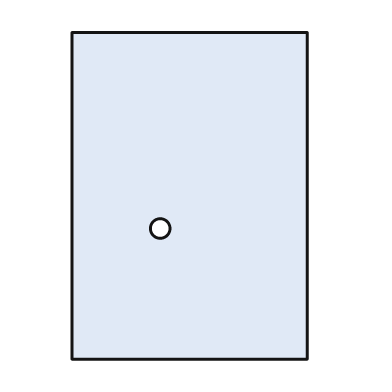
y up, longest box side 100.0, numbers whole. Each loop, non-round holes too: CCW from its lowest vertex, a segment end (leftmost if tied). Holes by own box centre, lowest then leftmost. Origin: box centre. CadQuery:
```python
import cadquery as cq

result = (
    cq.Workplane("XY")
    .moveTo(-36.0, -50.0)
    .lineTo(36.0, -50.0)
    .lineTo(36.0, 50.0)
    .lineTo(-36.0, 50.0)
    .close()
    .moveTo(-9.0, -10.0)
    .circle(3.0)
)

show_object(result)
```